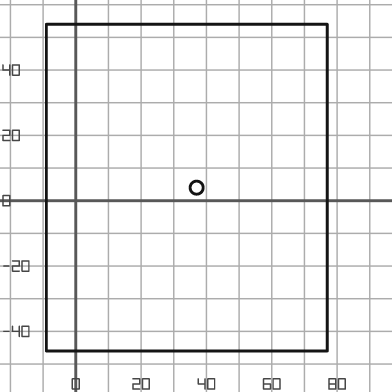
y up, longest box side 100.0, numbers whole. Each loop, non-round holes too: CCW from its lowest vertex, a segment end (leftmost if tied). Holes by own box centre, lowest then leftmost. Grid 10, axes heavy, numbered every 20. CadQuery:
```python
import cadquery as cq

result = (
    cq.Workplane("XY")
    .moveTo(-9.0, -46.0)
    .lineTo(77.0, -46.0)
    .lineTo(77.0, 54.0)
    .lineTo(-9.0, 54.0)
    .close()
    .moveTo(37.0, 4.0)
    .circle(2.0)
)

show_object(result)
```